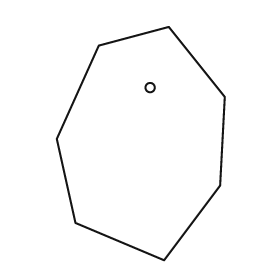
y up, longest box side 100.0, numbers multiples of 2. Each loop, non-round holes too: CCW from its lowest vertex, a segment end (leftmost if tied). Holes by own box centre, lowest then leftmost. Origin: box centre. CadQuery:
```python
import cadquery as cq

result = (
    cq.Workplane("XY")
    .moveTo(10.0, -50.0)
    .lineTo(34.0, -18.0)
    .lineTo(36.0, 20.0)
    .lineTo(12.0, 50.0)
    .lineTo(-18.0, 42.0)
    .lineTo(-36.0, 2.0)
    .lineTo(-28.0, -34.0)
    .close()
    .moveTo(4.0, 24.0)
    .circle(2.0)
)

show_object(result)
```